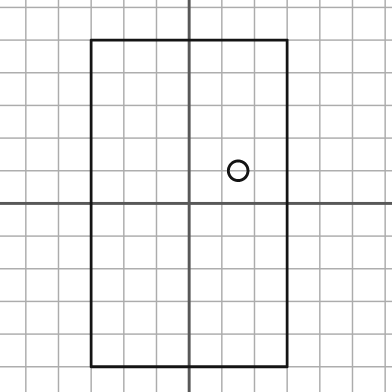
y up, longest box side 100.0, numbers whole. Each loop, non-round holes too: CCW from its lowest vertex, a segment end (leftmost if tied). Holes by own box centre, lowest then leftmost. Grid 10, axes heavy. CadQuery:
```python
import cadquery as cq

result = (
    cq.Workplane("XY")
    .moveTo(-30.0, -50.0)
    .lineTo(30.0, -50.0)
    .lineTo(30.0, 50.0)
    .lineTo(-30.0, 50.0)
    .close()
    .moveTo(15.0, 10.0)
    .circle(3.0)
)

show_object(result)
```